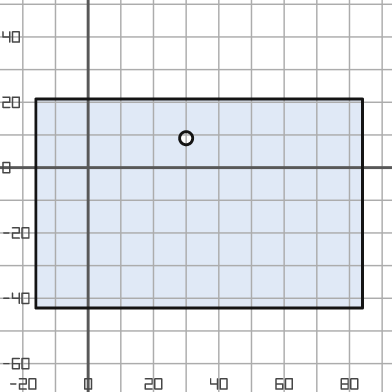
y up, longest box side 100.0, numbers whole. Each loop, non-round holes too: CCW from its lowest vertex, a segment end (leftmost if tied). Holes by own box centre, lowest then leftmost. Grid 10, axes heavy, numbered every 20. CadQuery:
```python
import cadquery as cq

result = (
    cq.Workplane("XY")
    .moveTo(-16.0, -43.0)
    .lineTo(84.0, -43.0)
    .lineTo(84.0, 21.0)
    .lineTo(-16.0, 21.0)
    .close()
    .moveTo(30.0, 9.0)
    .circle(2.0)
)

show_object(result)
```